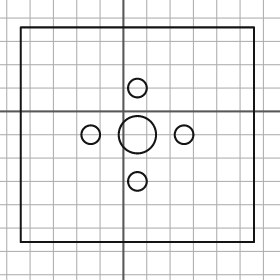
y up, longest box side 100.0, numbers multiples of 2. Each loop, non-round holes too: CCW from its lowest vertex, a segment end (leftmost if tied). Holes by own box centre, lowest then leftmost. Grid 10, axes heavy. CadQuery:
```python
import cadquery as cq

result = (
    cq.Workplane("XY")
    .moveTo(-44.0, -56.0)
    .lineTo(56.0, -56.0)
    .lineTo(56.0, 36.0)
    .lineTo(-44.0, 36.0)
    .close()
    .moveTo(6.0, -30.0)
    .circle(4.0)
    .moveTo(-14.0, -10.0)
    .circle(4.0)
    .moveTo(6.0, -10.0)
    .circle(8.0)
    .moveTo(26.0, -10.0)
    .circle(4.0)
    .moveTo(6.0, 10.0)
    .circle(4.0)
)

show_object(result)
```